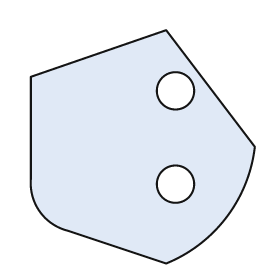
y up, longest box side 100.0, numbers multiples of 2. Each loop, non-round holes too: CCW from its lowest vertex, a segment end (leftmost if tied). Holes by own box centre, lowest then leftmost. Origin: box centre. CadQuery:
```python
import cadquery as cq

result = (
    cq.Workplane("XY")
    .moveTo(10.0, -50.0)
    .threePointArc((36.0, -30.0), (48.0, 0.0))
    .lineTo(10.0, 50.0)
    .lineTo(-48.0, 30.0)
    .lineTo(-48.0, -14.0)
    .threePointArc((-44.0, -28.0), (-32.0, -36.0))
    .close()
    .moveTo(14.0, -16.0)
    .circle(8.0)
    .moveTo(14.0, 24.0)
    .circle(8.0)
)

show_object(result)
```